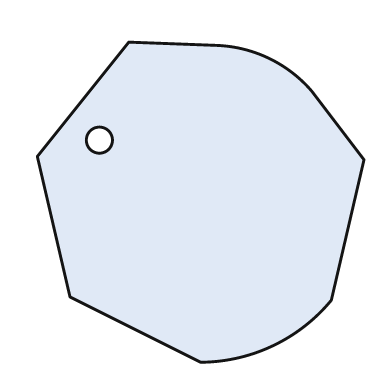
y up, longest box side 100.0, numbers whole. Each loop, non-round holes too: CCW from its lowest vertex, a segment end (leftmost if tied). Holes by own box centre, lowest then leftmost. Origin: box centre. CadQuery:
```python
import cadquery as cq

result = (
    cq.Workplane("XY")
    .moveTo(0.0, -49.0)
    .threePointArc((22.0, -44.0), (40.0, -30.0))
    .lineTo(50.0, 13.0)
    .lineTo(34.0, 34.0)
    .threePointArc((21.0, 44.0), (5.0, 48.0))
    .lineTo(-22.0, 49.0)
    .lineTo(-50.0, 14.0)
    .lineTo(-40.0, -29.0)
    .close()
    .moveTo(-31.0, 19.0)
    .circle(4.0)
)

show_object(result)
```